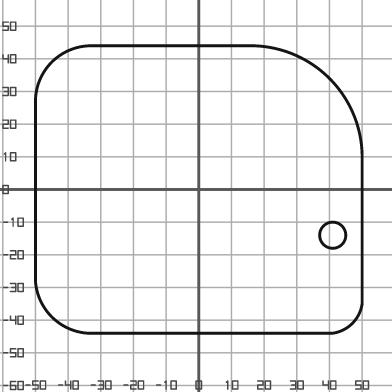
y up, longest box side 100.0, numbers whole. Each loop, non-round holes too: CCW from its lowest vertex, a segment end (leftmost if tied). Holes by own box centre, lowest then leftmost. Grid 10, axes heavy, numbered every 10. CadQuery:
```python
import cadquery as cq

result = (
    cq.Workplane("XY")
    .moveTo(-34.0, -44.0)
    .lineTo(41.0, -44.0)
    .threePointArc((47.0, -41.0), (50.0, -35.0))
    .lineTo(50.0, 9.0)
    .threePointArc((40.0, 34.0), (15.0, 44.0))
    .lineTo(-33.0, 44.0)
    .threePointArc((-45.0, 39.0), (-50.0, 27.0))
    .lineTo(-50.0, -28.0)
    .threePointArc((-45.0, -39.0), (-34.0, -44.0))
    .close()
    .moveTo(41.0, -14.0)
    .circle(4.0)
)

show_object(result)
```